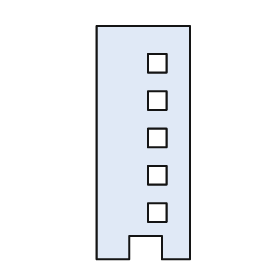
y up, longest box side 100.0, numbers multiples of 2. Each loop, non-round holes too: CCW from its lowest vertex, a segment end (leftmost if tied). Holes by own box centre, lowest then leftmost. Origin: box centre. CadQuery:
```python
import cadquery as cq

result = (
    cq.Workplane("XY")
    .moveTo(-20.0, -50.0)
    .lineTo(-6.0, -50.0)
    .lineTo(-6.0, -40.0)
    .lineTo(8.0, -40.0)
    .lineTo(8.0, -50.0)
    .lineTo(20.0, -50.0)
    .lineTo(20.0, 50.0)
    .lineTo(-20.0, 50.0)
    .close()
    .moveTo(2.0, -34.0)
    .lineTo(10.0, -34.0)
    .lineTo(10.0, -26.0)
    .lineTo(2.0, -26.0)
    .close()
    .moveTo(2.0, -18.0)
    .lineTo(10.0, -18.0)
    .lineTo(10.0, -10.0)
    .lineTo(2.0, -10.0)
    .close()
    .moveTo(2.0, -2.0)
    .lineTo(10.0, -2.0)
    .lineTo(10.0, 6.0)
    .lineTo(2.0, 6.0)
    .close()
    .moveTo(2.0, 14.0)
    .lineTo(10.0, 14.0)
    .lineTo(10.0, 22.0)
    .lineTo(2.0, 22.0)
    .close()
    .moveTo(2.0, 30.0)
    .lineTo(10.0, 30.0)
    .lineTo(10.0, 38.0)
    .lineTo(2.0, 38.0)
    .close()
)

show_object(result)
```